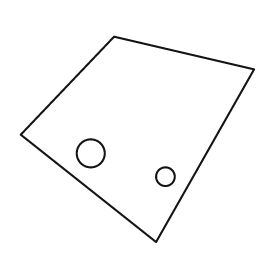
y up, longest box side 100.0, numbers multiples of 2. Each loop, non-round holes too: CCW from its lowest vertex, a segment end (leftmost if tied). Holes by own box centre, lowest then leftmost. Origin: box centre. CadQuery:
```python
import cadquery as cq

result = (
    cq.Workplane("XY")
    .moveTo(8.0, -44.0)
    .lineTo(50.0, 30.0)
    .lineTo(-10.0, 44.0)
    .lineTo(-50.0, 2.0)
    .close()
    .moveTo(12.0, -16.0)
    .circle(4.0)
    .moveTo(-20.0, -6.0)
    .circle(6.0)
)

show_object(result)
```